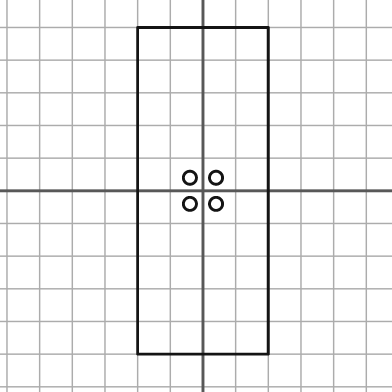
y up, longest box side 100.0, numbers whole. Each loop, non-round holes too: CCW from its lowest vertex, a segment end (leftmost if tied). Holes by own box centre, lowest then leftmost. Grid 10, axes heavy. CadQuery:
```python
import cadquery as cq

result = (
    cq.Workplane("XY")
    .moveTo(-20.0, -50.0)
    .lineTo(20.0, -50.0)
    .lineTo(20.0, 50.0)
    .lineTo(-20.0, 50.0)
    .close()
    .moveTo(-4.0, -4.0)
    .circle(2.0)
    .moveTo(4.0, -4.0)
    .circle(2.0)
    .moveTo(-4.0, 4.0)
    .circle(2.0)
    .moveTo(4.0, 4.0)
    .circle(2.0)
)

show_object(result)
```